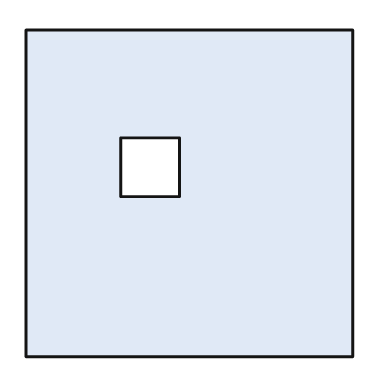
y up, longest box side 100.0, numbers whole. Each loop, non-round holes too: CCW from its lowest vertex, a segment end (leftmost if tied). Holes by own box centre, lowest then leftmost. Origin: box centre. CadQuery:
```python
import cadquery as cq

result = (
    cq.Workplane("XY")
    .moveTo(-50.0, -50.0)
    .lineTo(50.0, -50.0)
    .lineTo(50.0, 50.0)
    .lineTo(-50.0, 50.0)
    .close()
    .moveTo(-21.0, -1.0)
    .lineTo(-3.0, -1.0)
    .lineTo(-3.0, 17.0)
    .lineTo(-21.0, 17.0)
    .close()
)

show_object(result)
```